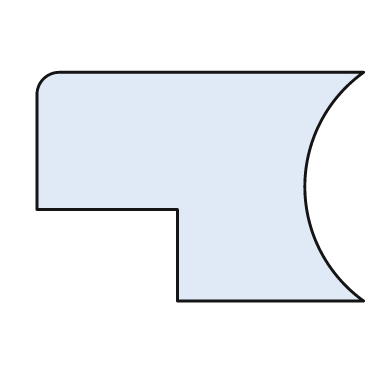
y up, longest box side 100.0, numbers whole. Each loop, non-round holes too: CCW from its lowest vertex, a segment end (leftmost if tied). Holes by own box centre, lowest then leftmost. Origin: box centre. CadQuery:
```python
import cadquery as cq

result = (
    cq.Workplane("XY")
    .moveTo(-7.0, -35.0)
    .lineTo(50.0, -35.0)
    .threePointArc((32.0, 0.0), (50.0, 35.0))
    .lineTo(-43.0, 35.0)
    .threePointArc((-48.0, 33.0), (-50.0, 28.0))
    .lineTo(-50.0, -7.0)
    .lineTo(-7.0, -7.0)
    .close()
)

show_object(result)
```